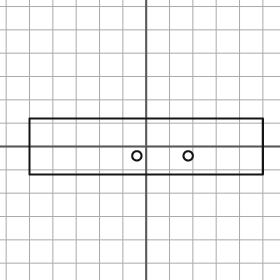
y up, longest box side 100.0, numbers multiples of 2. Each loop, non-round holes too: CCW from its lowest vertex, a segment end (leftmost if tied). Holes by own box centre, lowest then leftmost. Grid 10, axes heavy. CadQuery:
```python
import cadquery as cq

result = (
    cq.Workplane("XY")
    .moveTo(-50.0, -12.0)
    .lineTo(50.0, -12.0)
    .lineTo(50.0, 12.0)
    .lineTo(-50.0, 12.0)
    .close()
    .moveTo(-4.0, -4.0)
    .circle(2.0)
    .moveTo(18.0, -4.0)
    .circle(2.0)
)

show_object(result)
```